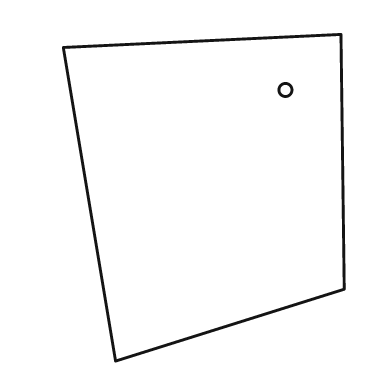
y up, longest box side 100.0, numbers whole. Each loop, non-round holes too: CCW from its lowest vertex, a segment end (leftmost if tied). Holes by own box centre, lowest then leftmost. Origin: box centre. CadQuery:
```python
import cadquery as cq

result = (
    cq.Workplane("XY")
    .moveTo(-27.0, -50.0)
    .lineTo(43.0, -28.0)
    .lineTo(42.0, 50.0)
    .lineTo(-43.0, 46.0)
    .close()
    .moveTo(25.0, 33.0)
    .circle(2.0)
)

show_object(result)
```